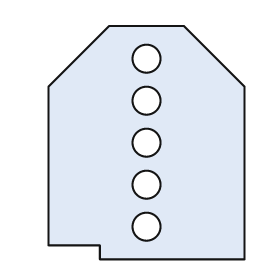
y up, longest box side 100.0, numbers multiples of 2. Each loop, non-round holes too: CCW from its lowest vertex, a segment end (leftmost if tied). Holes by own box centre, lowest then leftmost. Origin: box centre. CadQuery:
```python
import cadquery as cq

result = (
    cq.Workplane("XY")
    .moveTo(-20.0, -50.0)
    .lineTo(42.0, -50.0)
    .lineTo(42.0, 24.0)
    .lineTo(16.0, 50.0)
    .lineTo(-16.0, 50.0)
    .lineTo(-42.0, 24.0)
    .lineTo(-42.0, -44.0)
    .lineTo(-20.0, -44.0)
    .close()
    .moveTo(0.0, -36.0)
    .circle(6.0)
    .moveTo(0.0, -18.0)
    .circle(6.0)
    .moveTo(0.0, 0.0)
    .circle(6.0)
    .moveTo(0.0, 18.0)
    .circle(6.0)
    .moveTo(0.0, 36.0)
    .circle(6.0)
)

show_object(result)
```